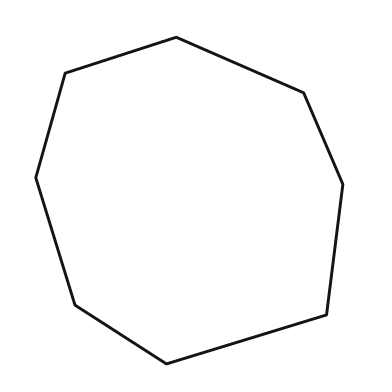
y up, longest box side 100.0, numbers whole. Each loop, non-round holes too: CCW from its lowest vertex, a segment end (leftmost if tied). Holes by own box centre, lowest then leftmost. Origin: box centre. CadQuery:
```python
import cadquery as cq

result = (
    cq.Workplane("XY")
    .moveTo(-7.0, -50.0)
    .lineTo(42.0, -35.0)
    .lineTo(47.0, 5.0)
    .lineTo(35.0, 33.0)
    .lineTo(-4.0, 50.0)
    .lineTo(-38.0, 39.0)
    .lineTo(-47.0, 7.0)
    .lineTo(-35.0, -32.0)
    .close()
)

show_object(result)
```